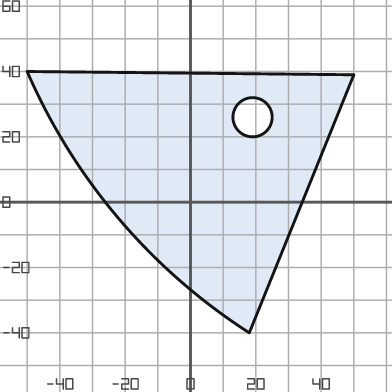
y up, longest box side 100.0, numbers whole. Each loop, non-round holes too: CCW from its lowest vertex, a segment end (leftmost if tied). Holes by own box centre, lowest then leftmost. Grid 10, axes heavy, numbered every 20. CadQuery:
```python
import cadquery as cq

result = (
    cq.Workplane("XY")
    .moveTo(18.0, -40.0)
    .lineTo(50.0, 39.0)
    .lineTo(-50.0, 40.0)
    .threePointArc((-22.0, -5.0), (18.0, -40.0))
    .close()
    .moveTo(19.0, 26.0)
    .circle(6.0)
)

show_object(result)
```